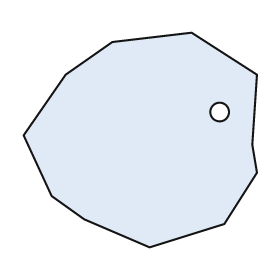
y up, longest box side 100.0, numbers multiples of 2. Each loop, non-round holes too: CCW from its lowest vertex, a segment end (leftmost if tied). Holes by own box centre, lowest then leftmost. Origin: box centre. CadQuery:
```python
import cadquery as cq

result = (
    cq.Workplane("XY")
    .moveTo(4.0, -46.0)
    .lineTo(36.0, -36.0)
    .lineTo(50.0, -14.0)
    .lineTo(48.0, -2.0)
    .lineTo(50.0, 28.0)
    .lineTo(22.0, 46.0)
    .lineTo(-12.0, 42.0)
    .lineTo(-32.0, 28.0)
    .lineTo(-50.0, 2.0)
    .lineTo(-38.0, -24.0)
    .lineTo(-24.0, -34.0)
    .close()
    .moveTo(34.0, 12.0)
    .circle(4.0)
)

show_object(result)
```